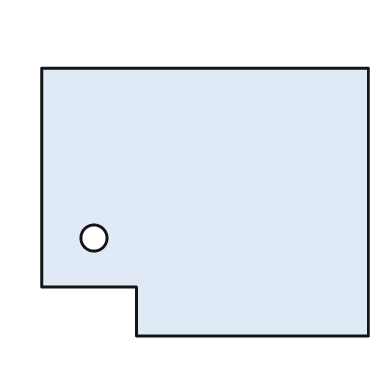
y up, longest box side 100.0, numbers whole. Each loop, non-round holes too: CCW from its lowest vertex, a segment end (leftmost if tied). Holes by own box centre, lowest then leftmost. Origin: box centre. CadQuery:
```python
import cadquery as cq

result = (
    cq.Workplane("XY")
    .moveTo(-21.0, -41.0)
    .lineTo(50.0, -41.0)
    .lineTo(50.0, 41.0)
    .lineTo(-50.0, 41.0)
    .lineTo(-50.0, -26.0)
    .lineTo(-21.0, -26.0)
    .close()
    .moveTo(-34.0, -11.0)
    .circle(4.0)
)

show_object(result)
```